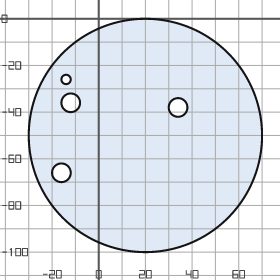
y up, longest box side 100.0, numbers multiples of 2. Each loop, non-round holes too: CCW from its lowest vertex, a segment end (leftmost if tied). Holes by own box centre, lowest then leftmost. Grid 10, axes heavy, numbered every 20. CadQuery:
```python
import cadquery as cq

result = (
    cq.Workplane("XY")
    .moveTo(20.0, -50.0)
    .circle(50.0)
    .moveTo(-16.0, -66.0)
    .circle(4.0)
    .moveTo(34.0, -38.0)
    .circle(4.0)
    .moveTo(-12.0, -36.0)
    .circle(4.0)
    .moveTo(-14.0, -26.0)
    .circle(2.0)
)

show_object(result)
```